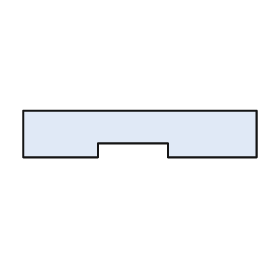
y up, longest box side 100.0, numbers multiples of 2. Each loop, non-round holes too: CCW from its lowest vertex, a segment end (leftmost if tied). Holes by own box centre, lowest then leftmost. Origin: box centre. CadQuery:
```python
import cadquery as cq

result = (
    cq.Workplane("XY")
    .moveTo(-50.0, -10.0)
    .lineTo(-18.0, -10.0)
    .lineTo(-18.0, -4.0)
    .lineTo(12.0, -4.0)
    .lineTo(12.0, -10.0)
    .lineTo(50.0, -10.0)
    .lineTo(50.0, 10.0)
    .lineTo(-50.0, 10.0)
    .close()
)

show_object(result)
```